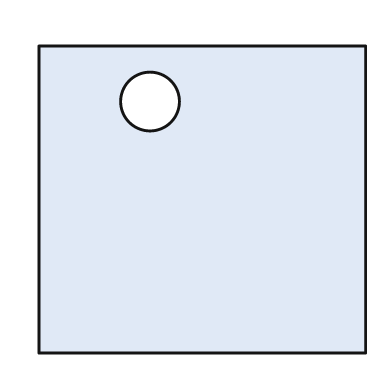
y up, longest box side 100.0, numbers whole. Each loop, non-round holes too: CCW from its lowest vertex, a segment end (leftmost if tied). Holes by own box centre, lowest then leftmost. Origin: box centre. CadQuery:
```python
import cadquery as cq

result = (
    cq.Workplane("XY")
    .moveTo(-50.0, -47.0)
    .lineTo(50.0, -47.0)
    .lineTo(50.0, 47.0)
    .lineTo(-50.0, 47.0)
    .close()
    .moveTo(-16.0, 30.0)
    .circle(9.0)
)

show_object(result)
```